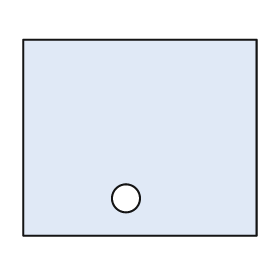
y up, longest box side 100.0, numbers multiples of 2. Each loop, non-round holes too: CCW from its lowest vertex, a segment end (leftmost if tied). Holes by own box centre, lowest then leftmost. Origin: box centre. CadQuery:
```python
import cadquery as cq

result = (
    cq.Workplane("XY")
    .moveTo(-50.0, -42.0)
    .lineTo(50.0, -42.0)
    .lineTo(50.0, 42.0)
    .lineTo(-50.0, 42.0)
    .close()
    .moveTo(-6.0, -26.0)
    .circle(6.0)
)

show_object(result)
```